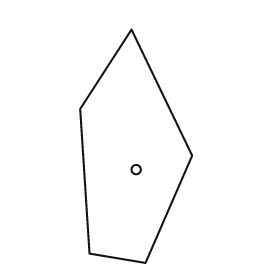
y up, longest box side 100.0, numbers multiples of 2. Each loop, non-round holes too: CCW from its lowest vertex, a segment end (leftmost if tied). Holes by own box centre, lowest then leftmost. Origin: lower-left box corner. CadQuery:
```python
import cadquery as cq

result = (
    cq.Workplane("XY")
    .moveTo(28.0, 0.0)
    .lineTo(48.0, 46.0)
    .lineTo(22.0, 100.0)
    .lineTo(0.0, 66.0)
    .lineTo(4.0, 4.0)
    .close()
    .moveTo(24.0, 40.0)
    .circle(2.0)
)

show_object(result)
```